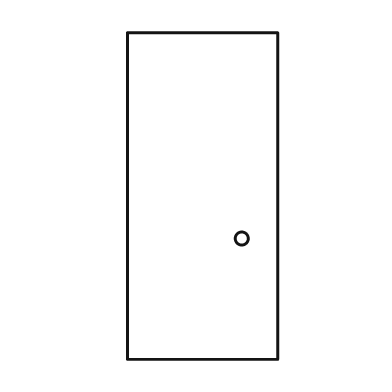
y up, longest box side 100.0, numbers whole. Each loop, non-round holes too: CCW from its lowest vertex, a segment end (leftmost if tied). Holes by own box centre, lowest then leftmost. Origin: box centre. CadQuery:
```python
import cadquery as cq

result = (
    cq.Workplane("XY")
    .moveTo(-23.0, -50.0)
    .lineTo(23.0, -50.0)
    .lineTo(23.0, 50.0)
    .lineTo(-23.0, 50.0)
    .close()
    .moveTo(12.0, -13.0)
    .circle(2.0)
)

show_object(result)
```